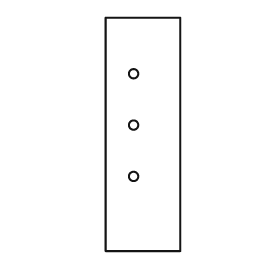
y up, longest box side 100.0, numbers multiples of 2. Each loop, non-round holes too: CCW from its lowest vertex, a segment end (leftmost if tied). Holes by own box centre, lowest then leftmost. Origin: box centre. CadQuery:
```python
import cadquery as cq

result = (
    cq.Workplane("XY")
    .moveTo(-16.0, -50.0)
    .lineTo(16.0, -50.0)
    .lineTo(16.0, 50.0)
    .lineTo(-16.0, 50.0)
    .close()
    .moveTo(-4.0, -18.0)
    .circle(2.0)
    .moveTo(-4.0, 4.0)
    .circle(2.0)
    .moveTo(-4.0, 26.0)
    .circle(2.0)
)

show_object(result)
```